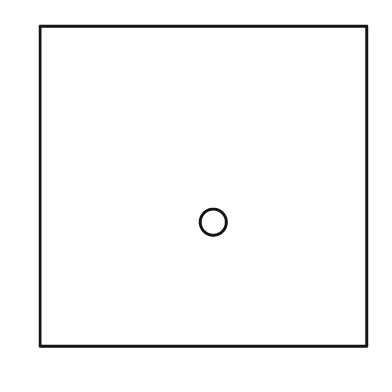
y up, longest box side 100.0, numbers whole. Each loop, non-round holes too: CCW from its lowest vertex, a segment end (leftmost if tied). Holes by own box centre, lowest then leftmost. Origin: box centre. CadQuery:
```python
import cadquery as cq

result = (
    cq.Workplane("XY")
    .moveTo(-50.0, -49.0)
    .lineTo(50.0, -49.0)
    .lineTo(50.0, 49.0)
    .lineTo(-50.0, 49.0)
    .close()
    .moveTo(3.0, -11.0)
    .circle(4.0)
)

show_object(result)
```